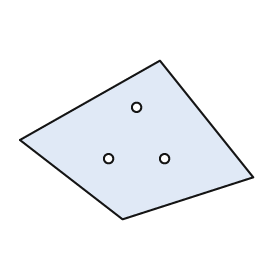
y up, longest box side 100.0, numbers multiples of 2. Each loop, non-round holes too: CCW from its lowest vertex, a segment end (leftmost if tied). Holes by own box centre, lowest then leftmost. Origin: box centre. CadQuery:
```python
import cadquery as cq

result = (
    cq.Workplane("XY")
    .moveTo(-6.0, -34.0)
    .lineTo(50.0, -16.0)
    .lineTo(10.0, 34.0)
    .lineTo(-50.0, 0.0)
    .close()
    .moveTo(-12.0, -8.0)
    .circle(2.0)
    .moveTo(12.0, -8.0)
    .circle(2.0)
    .moveTo(0.0, 14.0)
    .circle(2.0)
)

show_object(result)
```